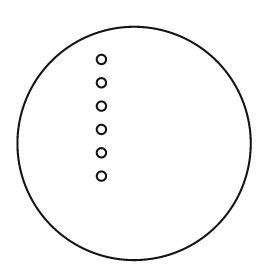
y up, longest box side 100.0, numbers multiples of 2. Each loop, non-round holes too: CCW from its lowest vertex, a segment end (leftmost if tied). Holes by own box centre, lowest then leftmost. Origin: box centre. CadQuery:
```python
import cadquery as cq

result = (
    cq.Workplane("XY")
    .moveTo(0.0, 0.0)
    .circle(50.0)
    .moveTo(-14.0, -14.0)
    .circle(2.0)
    .moveTo(-14.0, -4.0)
    .circle(2.0)
    .moveTo(-14.0, 6.0)
    .circle(2.0)
    .moveTo(-14.0, 16.0)
    .circle(2.0)
    .moveTo(-14.0, 26.0)
    .circle(2.0)
    .moveTo(-14.0, 36.0)
    .circle(2.0)
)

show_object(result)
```